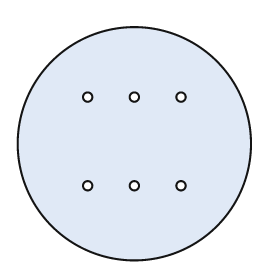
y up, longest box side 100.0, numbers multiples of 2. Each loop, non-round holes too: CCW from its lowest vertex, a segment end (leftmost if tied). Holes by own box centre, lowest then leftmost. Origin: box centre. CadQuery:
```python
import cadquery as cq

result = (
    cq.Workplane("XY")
    .moveTo(0.0, 0.0)
    .circle(50.0)
    .moveTo(-20.0, -18.0)
    .circle(2.0)
    .moveTo(0.0, -18.0)
    .circle(2.0)
    .moveTo(20.0, -18.0)
    .circle(2.0)
    .moveTo(-20.0, 20.0)
    .circle(2.0)
    .moveTo(0.0, 20.0)
    .circle(2.0)
    .moveTo(20.0, 20.0)
    .circle(2.0)
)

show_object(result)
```